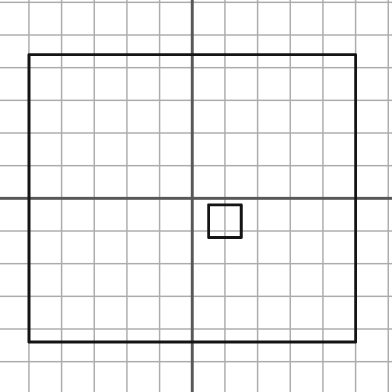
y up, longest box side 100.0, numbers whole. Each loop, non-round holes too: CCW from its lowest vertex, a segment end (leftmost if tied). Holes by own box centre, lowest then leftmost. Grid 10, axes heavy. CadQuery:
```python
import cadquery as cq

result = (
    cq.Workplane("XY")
    .moveTo(-50.0, -44.0)
    .lineTo(50.0, -44.0)
    .lineTo(50.0, 44.0)
    .lineTo(-50.0, 44.0)
    .close()
    .moveTo(5.0, -12.0)
    .lineTo(15.0, -12.0)
    .lineTo(15.0, -2.0)
    .lineTo(5.0, -2.0)
    .close()
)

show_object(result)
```